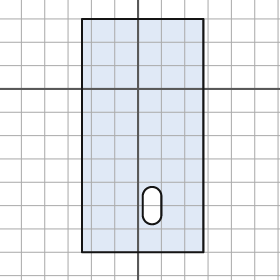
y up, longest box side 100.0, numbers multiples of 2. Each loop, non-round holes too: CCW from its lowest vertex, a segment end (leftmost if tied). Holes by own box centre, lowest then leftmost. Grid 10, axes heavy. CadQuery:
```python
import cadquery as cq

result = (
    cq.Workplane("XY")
    .moveTo(-24.0, -70.0)
    .lineTo(28.0, -70.0)
    .lineTo(28.0, 30.0)
    .lineTo(-24.0, 30.0)
    .close()
    .moveTo(2.0, -54.0)
    .threePointArc((6.0, -58.0), (10.0, -54.0))
    .lineTo(10.0, -46.0)
    .threePointArc((6.0, -42.0), (2.0, -46.0))
    .close()
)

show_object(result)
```